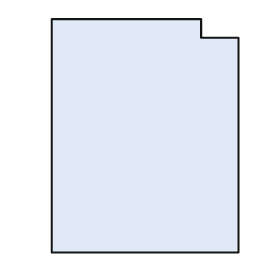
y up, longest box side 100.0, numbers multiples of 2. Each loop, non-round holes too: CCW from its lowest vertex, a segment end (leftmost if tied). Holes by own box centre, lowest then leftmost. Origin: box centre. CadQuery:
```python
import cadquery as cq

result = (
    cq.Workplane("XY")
    .moveTo(-40.0, -50.0)
    .lineTo(40.0, -50.0)
    .lineTo(40.0, 42.0)
    .lineTo(24.0, 42.0)
    .lineTo(24.0, 50.0)
    .lineTo(-40.0, 50.0)
    .close()
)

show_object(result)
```